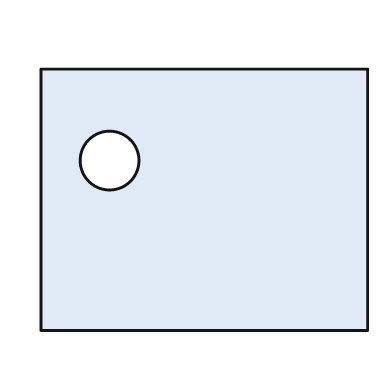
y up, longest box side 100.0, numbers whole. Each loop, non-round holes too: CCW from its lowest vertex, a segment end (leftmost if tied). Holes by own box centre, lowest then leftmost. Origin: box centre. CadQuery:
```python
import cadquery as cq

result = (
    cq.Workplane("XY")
    .moveTo(-50.0, -40.0)
    .lineTo(50.0, -40.0)
    .lineTo(50.0, 40.0)
    .lineTo(-50.0, 40.0)
    .close()
    .moveTo(-29.0, 12.0)
    .circle(9.0)
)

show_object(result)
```